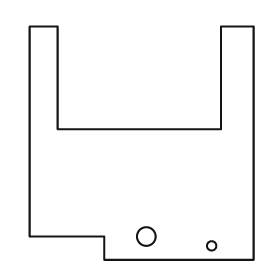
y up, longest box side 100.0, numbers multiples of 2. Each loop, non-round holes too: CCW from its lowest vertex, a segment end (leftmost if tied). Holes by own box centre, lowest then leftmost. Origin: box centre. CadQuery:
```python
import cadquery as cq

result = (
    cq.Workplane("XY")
    .moveTo(-16.0, -50.0)
    .lineTo(48.0, -50.0)
    .lineTo(48.0, 50.0)
    .lineTo(34.0, 50.0)
    .lineTo(34.0, 6.0)
    .lineTo(-36.0, 6.0)
    .lineTo(-36.0, 50.0)
    .lineTo(-48.0, 50.0)
    .lineTo(-48.0, -40.0)
    .lineTo(-16.0, -40.0)
    .close()
    .moveTo(30.0, -44.0)
    .circle(2.0)
    .moveTo(2.0, -40.0)
    .circle(4.0)
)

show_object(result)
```